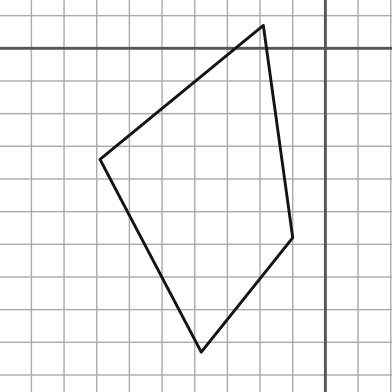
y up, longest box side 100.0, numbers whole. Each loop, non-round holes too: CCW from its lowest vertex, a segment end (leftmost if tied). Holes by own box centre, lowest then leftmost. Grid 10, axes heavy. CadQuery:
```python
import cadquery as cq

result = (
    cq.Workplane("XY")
    .moveTo(-38.0, -93.0)
    .lineTo(-10.0, -58.0)
    .lineTo(-19.0, 7.0)
    .lineTo(-69.0, -34.0)
    .close()
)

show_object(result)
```